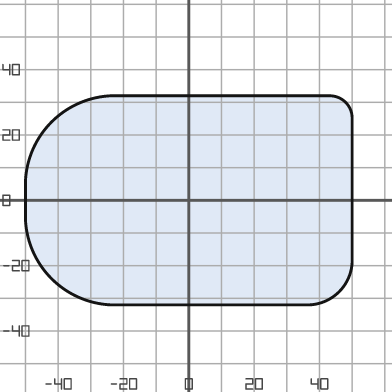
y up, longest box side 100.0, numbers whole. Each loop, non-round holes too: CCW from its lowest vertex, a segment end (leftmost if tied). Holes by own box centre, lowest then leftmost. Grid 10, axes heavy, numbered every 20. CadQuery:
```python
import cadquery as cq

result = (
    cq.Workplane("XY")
    .moveTo(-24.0, -32.0)
    .lineTo(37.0, -32.0)
    .threePointArc((46.0, -28.0), (50.0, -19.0))
    .lineTo(50.0, 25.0)
    .threePointArc((48.0, 30.0), (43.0, 32.0))
    .lineTo(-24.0, 32.0)
    .threePointArc((-42.0, 24.0), (-50.0, 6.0))
    .lineTo(-50.0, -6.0)
    .threePointArc((-42.0, -24.0), (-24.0, -32.0))
    .close()
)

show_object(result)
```